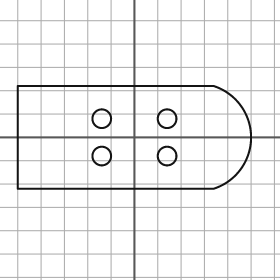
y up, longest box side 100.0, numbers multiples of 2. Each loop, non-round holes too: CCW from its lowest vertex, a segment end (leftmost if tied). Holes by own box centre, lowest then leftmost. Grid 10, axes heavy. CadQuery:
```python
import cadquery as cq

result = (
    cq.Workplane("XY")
    .moveTo(-50.0, -22.0)
    .lineTo(34.0, -22.0)
    .threePointArc((50.0, 0.0), (34.0, 22.0))
    .lineTo(-50.0, 22.0)
    .close()
    .moveTo(-14.0, -8.0)
    .circle(4.0)
    .moveTo(14.0, -8.0)
    .circle(4.0)
    .moveTo(-14.0, 8.0)
    .circle(4.0)
    .moveTo(14.0, 8.0)
    .circle(4.0)
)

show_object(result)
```